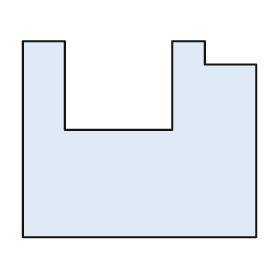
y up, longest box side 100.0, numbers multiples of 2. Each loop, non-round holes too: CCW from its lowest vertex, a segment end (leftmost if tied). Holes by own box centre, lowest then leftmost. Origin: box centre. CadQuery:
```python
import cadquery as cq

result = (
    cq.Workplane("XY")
    .moveTo(-50.0, -42.0)
    .lineTo(50.0, -42.0)
    .lineTo(50.0, 32.0)
    .lineTo(28.0, 32.0)
    .lineTo(28.0, 42.0)
    .lineTo(14.0, 42.0)
    .lineTo(14.0, 4.0)
    .lineTo(-32.0, 4.0)
    .lineTo(-32.0, 42.0)
    .lineTo(-50.0, 42.0)
    .close()
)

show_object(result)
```